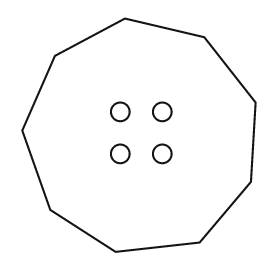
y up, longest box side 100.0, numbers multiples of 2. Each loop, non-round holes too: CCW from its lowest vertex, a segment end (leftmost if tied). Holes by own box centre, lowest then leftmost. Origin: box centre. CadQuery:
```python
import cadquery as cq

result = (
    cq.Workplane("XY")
    .moveTo(-10.0, -50.0)
    .lineTo(26.0, -46.0)
    .lineTo(48.0, -20.0)
    .lineTo(50.0, 14.0)
    .lineTo(28.0, 42.0)
    .lineTo(-6.0, 50.0)
    .lineTo(-36.0, 34.0)
    .lineTo(-50.0, 2.0)
    .lineTo(-38.0, -32.0)
    .close()
    .moveTo(-8.0, -8.0)
    .circle(4.0)
    .moveTo(10.0, -8.0)
    .circle(4.0)
    .moveTo(-8.0, 10.0)
    .circle(4.0)
    .moveTo(10.0, 10.0)
    .circle(4.0)
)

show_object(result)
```